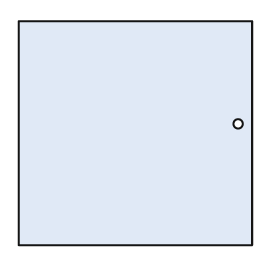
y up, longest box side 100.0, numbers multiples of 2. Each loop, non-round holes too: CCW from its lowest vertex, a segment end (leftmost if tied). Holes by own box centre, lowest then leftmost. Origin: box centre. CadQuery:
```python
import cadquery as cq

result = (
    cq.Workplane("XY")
    .moveTo(-50.0, -48.0)
    .lineTo(50.0, -48.0)
    .lineTo(50.0, 48.0)
    .lineTo(-50.0, 48.0)
    .close()
    .moveTo(44.0, 4.0)
    .circle(2.0)
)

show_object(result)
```